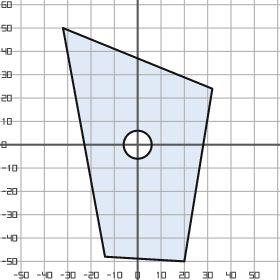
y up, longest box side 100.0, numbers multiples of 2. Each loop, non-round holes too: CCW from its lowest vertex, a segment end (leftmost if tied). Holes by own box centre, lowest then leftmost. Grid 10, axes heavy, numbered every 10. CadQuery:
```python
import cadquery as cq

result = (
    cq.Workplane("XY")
    .moveTo(20.0, -50.0)
    .lineTo(32.0, 24.0)
    .lineTo(-32.0, 50.0)
    .lineTo(-14.0, -48.0)
    .close()
    .moveTo(0.0, 0.0)
    .circle(6.0)
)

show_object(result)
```